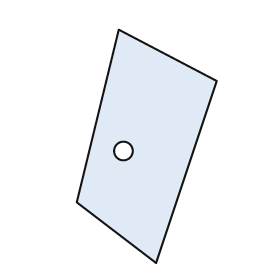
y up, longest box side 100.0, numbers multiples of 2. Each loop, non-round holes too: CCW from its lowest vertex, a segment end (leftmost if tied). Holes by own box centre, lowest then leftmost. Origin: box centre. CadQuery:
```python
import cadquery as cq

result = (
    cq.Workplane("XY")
    .moveTo(4.0, -50.0)
    .lineTo(30.0, 28.0)
    .lineTo(-12.0, 50.0)
    .lineTo(-30.0, -24.0)
    .close()
    .moveTo(-10.0, -2.0)
    .circle(4.0)
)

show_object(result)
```